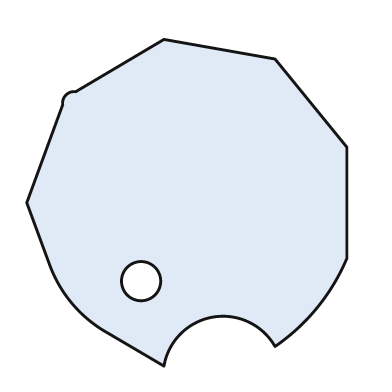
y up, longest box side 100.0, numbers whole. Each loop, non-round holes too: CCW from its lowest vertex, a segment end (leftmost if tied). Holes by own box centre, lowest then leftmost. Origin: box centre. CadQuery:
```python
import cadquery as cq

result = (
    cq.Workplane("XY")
    .moveTo(-7.0, -50.0)
    .threePointArc((8.0, -35.0), (27.0, -44.0))
    .threePointArc((40.0, -32.0), (49.0, -17.0))
    .lineTo(49.0, 17.0)
    .lineTo(27.0, 44.0)
    .lineTo(-7.0, 50.0)
    .lineTo(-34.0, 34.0)
    .threePointArc((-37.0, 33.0), (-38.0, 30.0))
    .lineTo(-49.0, 0.0)
    .lineTo(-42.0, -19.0)
    .threePointArc((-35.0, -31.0), (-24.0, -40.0))
    .close()
    .moveTo(-14.0, -24.0)
    .circle(6.0)
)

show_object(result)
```